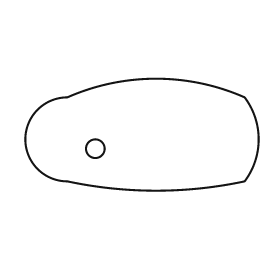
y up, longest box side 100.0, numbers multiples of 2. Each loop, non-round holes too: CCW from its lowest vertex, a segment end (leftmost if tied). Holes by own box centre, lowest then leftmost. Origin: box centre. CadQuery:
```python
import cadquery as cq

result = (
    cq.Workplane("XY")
    .moveTo(-32.0, -20.0)
    .threePointArc((6.0, -24.0), (44.0, -20.0))
    .threePointArc((50.0, -2.0), (44.0, 16.0))
    .threePointArc((6.0, 24.0), (-32.0, 16.0))
    .threePointArc((-50.0, -2.0), (-32.0, -20.0))
    .close()
    .moveTo(-20.0, -6.0)
    .circle(4.0)
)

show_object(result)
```